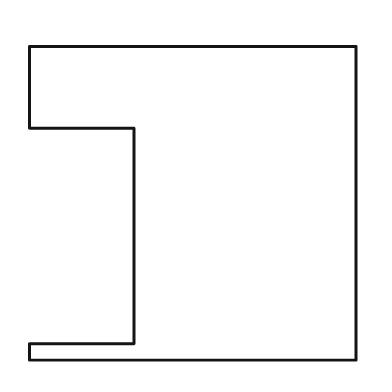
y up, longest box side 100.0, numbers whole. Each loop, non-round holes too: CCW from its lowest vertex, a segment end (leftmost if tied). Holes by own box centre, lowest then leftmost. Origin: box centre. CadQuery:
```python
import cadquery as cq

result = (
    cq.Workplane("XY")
    .moveTo(-50.0, -48.0)
    .lineTo(50.0, -48.0)
    .lineTo(50.0, 48.0)
    .lineTo(-50.0, 48.0)
    .lineTo(-50.0, 23.0)
    .lineTo(-18.0, 23.0)
    .lineTo(-18.0, -43.0)
    .lineTo(-50.0, -43.0)
    .close()
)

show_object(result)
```